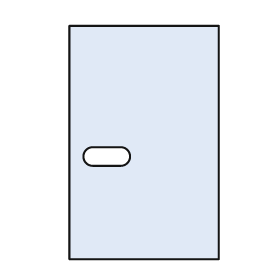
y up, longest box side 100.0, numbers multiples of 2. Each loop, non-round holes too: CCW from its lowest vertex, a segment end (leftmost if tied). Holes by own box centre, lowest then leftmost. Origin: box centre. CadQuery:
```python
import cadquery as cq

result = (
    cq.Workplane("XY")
    .moveTo(-32.0, -50.0)
    .lineTo(32.0, -50.0)
    .lineTo(32.0, 50.0)
    .lineTo(-32.0, 50.0)
    .close()
    .moveTo(-22.0, -10.0)
    .lineTo(-10.0, -10.0)
    .threePointArc((-6.0, -6.0), (-10.0, -2.0))
    .lineTo(-22.0, -2.0)
    .threePointArc((-26.0, -6.0), (-22.0, -10.0))
    .close()
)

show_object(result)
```